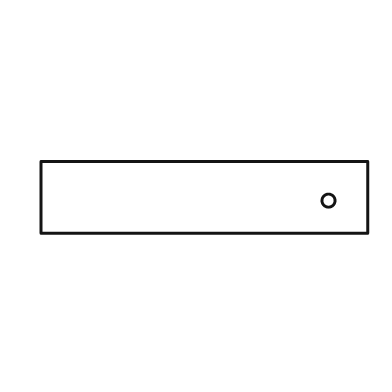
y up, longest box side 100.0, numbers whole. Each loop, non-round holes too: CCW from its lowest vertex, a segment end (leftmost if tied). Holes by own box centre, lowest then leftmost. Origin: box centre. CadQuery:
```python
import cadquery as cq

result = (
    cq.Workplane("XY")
    .moveTo(-50.0, -11.0)
    .lineTo(50.0, -11.0)
    .lineTo(50.0, 11.0)
    .lineTo(-50.0, 11.0)
    .close()
    .moveTo(38.0, -1.0)
    .circle(2.0)
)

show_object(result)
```